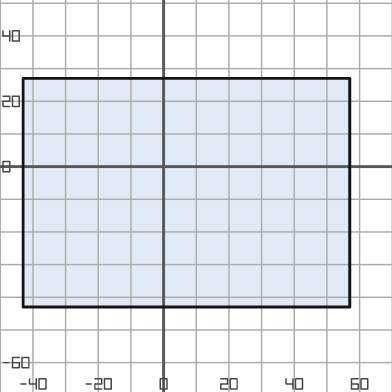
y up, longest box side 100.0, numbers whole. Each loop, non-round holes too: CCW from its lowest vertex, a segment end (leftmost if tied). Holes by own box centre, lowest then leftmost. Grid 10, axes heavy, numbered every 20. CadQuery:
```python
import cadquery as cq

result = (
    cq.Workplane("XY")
    .moveTo(-43.0, -43.0)
    .lineTo(57.0, -43.0)
    .lineTo(57.0, 27.0)
    .lineTo(-43.0, 27.0)
    .close()
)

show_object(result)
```